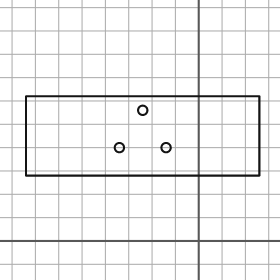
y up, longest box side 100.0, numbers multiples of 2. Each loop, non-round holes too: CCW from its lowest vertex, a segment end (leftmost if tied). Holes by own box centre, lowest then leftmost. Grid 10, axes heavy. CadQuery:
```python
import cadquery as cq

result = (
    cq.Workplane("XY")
    .moveTo(-74.0, 28.0)
    .lineTo(26.0, 28.0)
    .lineTo(26.0, 62.0)
    .lineTo(-74.0, 62.0)
    .close()
    .moveTo(-34.0, 40.0)
    .circle(2.0)
    .moveTo(-14.0, 40.0)
    .circle(2.0)
    .moveTo(-24.0, 56.0)
    .circle(2.0)
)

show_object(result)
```